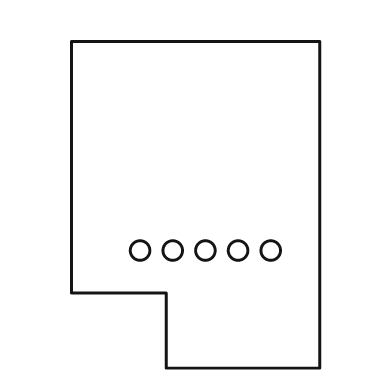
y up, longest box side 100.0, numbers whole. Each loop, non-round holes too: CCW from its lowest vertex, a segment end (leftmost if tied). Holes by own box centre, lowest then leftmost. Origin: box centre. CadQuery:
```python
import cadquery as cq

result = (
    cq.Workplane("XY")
    .moveTo(-9.0, -50.0)
    .lineTo(38.0, -50.0)
    .lineTo(38.0, 50.0)
    .lineTo(-38.0, 50.0)
    .lineTo(-38.0, -27.0)
    .lineTo(-9.0, -27.0)
    .close()
    .moveTo(-17.0, -14.0)
    .circle(3.0)
    .moveTo(-7.0, -14.0)
    .circle(3.0)
    .moveTo(3.0, -14.0)
    .circle(3.0)
    .moveTo(13.0, -14.0)
    .circle(3.0)
    .moveTo(23.0, -14.0)
    .circle(3.0)
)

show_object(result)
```